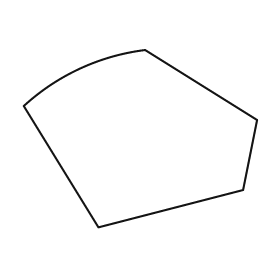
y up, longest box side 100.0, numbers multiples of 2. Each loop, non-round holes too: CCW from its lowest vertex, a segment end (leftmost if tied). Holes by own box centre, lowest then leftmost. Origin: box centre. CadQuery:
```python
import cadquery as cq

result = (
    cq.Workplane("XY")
    .moveTo(-18.0, -38.0)
    .lineTo(44.0, -22.0)
    .lineTo(50.0, 8.0)
    .lineTo(2.0, 38.0)
    .threePointArc((-26.0, 30.0), (-50.0, 14.0))
    .close()
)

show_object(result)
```